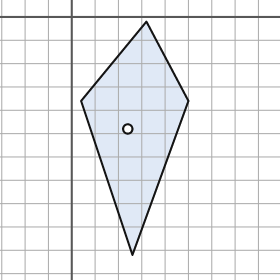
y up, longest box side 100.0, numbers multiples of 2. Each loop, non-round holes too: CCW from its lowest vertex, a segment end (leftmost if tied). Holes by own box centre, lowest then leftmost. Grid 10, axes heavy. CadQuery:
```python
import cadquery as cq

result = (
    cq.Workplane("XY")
    .moveTo(26.0, -102.0)
    .lineTo(50.0, -36.0)
    .lineTo(32.0, -2.0)
    .lineTo(4.0, -36.0)
    .close()
    .moveTo(24.0, -48.0)
    .circle(2.0)
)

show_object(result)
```